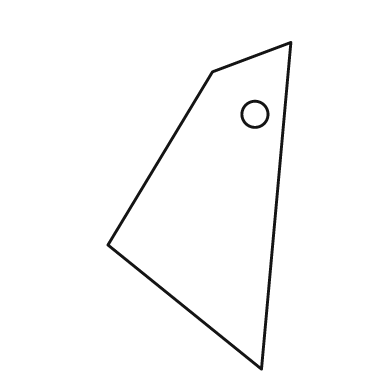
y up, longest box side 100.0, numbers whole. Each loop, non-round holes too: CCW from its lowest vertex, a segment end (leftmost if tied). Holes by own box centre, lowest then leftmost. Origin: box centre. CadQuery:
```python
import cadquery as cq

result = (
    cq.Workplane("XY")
    .moveTo(19.0, -50.0)
    .lineTo(28.0, 50.0)
    .lineTo(4.0, 41.0)
    .lineTo(-28.0, -12.0)
    .close()
    .moveTo(17.0, 28.0)
    .circle(4.0)
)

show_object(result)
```